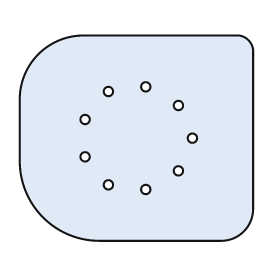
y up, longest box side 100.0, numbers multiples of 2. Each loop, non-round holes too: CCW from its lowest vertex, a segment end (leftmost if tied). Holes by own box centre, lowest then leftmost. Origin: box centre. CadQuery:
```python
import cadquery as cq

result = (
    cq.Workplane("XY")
    .moveTo(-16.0, -44.0)
    .lineTo(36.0, -44.0)
    .threePointArc((46.0, -40.0), (50.0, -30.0))
    .lineTo(50.0, 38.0)
    .threePointArc((48.0, 42.0), (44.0, 44.0))
    .lineTo(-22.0, 44.0)
    .threePointArc((-42.0, 36.0), (-50.0, 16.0))
    .lineTo(-50.0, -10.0)
    .threePointArc((-40.0, -34.0), (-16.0, -44.0))
    .close()
    .moveTo(4.0, -22.0)
    .circle(2.0)
    .moveTo(-12.0, -20.0)
    .circle(2.0)
    .moveTo(18.0, -14.0)
    .circle(2.0)
    .moveTo(-22.0, -8.0)
    .circle(2.0)
    .moveTo(24.0, 0.0)
    .circle(2.0)
    .moveTo(-22.0, 8.0)
    .circle(2.0)
    .moveTo(18.0, 14.0)
    .circle(2.0)
    .moveTo(-12.0, 20.0)
    .circle(2.0)
    .moveTo(4.0, 22.0)
    .circle(2.0)
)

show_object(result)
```